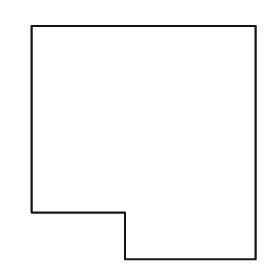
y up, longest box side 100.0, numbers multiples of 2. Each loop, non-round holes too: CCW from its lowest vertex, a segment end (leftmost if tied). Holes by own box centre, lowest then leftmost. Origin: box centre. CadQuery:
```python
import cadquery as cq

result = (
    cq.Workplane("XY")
    .moveTo(-8.0, -50.0)
    .lineTo(48.0, -50.0)
    .lineTo(48.0, 50.0)
    .lineTo(-48.0, 50.0)
    .lineTo(-48.0, -30.0)
    .lineTo(-8.0, -30.0)
    .close()
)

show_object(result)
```